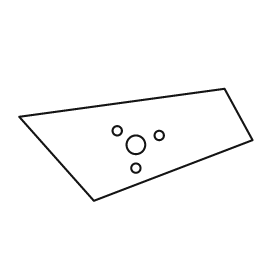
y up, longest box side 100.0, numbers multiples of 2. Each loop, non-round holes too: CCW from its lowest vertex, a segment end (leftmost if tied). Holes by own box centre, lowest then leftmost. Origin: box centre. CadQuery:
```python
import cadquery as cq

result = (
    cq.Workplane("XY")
    .moveTo(-18.0, -24.0)
    .lineTo(50.0, 2.0)
    .lineTo(38.0, 24.0)
    .lineTo(-50.0, 12.0)
    .close()
    .moveTo(0.0, -10.0)
    .circle(2.0)
    .moveTo(0.0, 0.0)
    .circle(4.0)
    .moveTo(10.0, 4.0)
    .circle(2.0)
    .moveTo(-8.0, 6.0)
    .circle(2.0)
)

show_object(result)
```